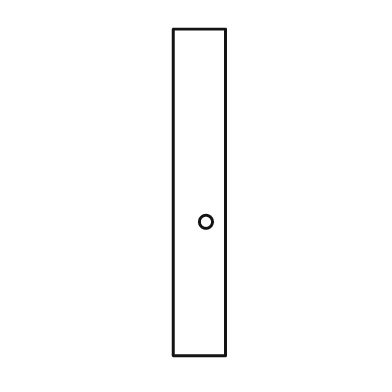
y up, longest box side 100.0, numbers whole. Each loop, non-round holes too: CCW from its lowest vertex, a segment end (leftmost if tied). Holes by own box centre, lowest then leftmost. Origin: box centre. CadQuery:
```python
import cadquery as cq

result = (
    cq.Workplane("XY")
    .moveTo(-8.0, -50.0)
    .lineTo(8.0, -50.0)
    .lineTo(8.0, 50.0)
    .lineTo(-8.0, 50.0)
    .close()
    .moveTo(2.0, -9.0)
    .circle(2.0)
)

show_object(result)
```